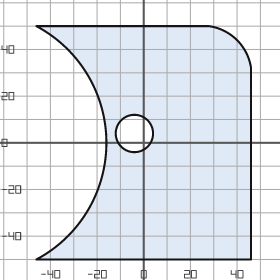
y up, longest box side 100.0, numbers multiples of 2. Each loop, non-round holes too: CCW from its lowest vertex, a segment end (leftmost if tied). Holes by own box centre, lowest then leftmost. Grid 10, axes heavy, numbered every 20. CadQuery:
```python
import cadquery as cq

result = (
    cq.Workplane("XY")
    .moveTo(-46.0, -50.0)
    .lineTo(46.0, -50.0)
    .lineTo(46.0, 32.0)
    .threePointArc((40.0, 44.0), (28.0, 50.0))
    .lineTo(-46.0, 50.0)
    .threePointArc((-16.0, 0.0), (-46.0, -50.0))
    .close()
    .moveTo(-4.0, 4.0)
    .circle(8.0)
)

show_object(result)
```